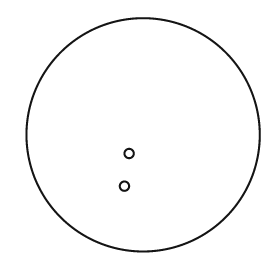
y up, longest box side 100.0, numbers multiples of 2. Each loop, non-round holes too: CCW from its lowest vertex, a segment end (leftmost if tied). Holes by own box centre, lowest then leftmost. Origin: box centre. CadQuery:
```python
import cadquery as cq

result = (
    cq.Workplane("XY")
    .moveTo(0.0, 0.0)
    .circle(50.0)
    .moveTo(-8.0, -22.0)
    .circle(2.0)
    .moveTo(-6.0, -8.0)
    .circle(2.0)
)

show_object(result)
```